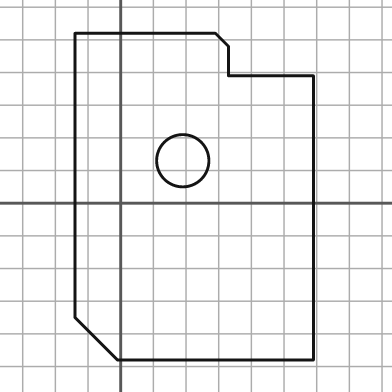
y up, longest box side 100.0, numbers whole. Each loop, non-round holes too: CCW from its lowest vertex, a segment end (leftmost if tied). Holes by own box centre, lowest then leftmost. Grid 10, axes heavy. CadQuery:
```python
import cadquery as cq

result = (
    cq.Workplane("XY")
    .moveTo(-1.0, -48.0)
    .lineTo(59.0, -48.0)
    .lineTo(59.0, 39.0)
    .lineTo(33.0, 39.0)
    .lineTo(33.0, 48.0)
    .lineTo(29.0, 52.0)
    .lineTo(-14.0, 52.0)
    .lineTo(-14.0, -35.0)
    .close()
    .moveTo(19.0, 13.0)
    .circle(8.0)
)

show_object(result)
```